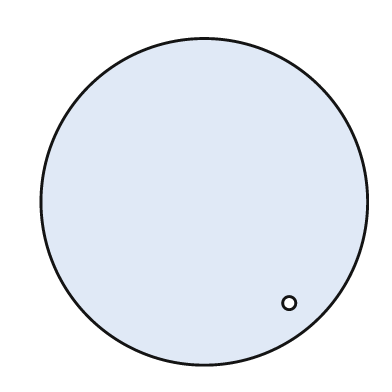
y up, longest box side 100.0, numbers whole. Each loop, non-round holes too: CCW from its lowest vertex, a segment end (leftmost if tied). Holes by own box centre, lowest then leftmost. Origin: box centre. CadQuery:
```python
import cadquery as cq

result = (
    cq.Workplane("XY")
    .moveTo(0.0, 0.0)
    .circle(50.0)
    .moveTo(26.0, -31.0)
    .circle(2.0)
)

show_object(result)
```